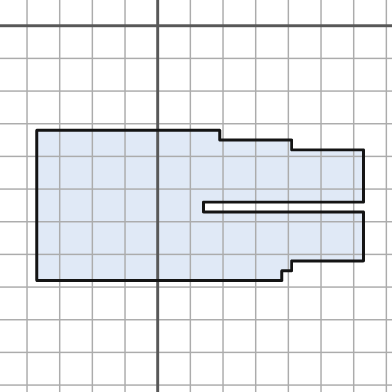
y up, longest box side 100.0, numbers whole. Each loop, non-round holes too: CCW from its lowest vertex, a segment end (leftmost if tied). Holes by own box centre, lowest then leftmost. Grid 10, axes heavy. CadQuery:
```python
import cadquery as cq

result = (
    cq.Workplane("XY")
    .moveTo(-37.0, -78.0)
    .lineTo(38.0, -78.0)
    .lineTo(38.0, -75.0)
    .lineTo(41.0, -75.0)
    .lineTo(41.0, -72.0)
    .lineTo(63.0, -72.0)
    .lineTo(63.0, -57.0)
    .lineTo(14.0, -57.0)
    .lineTo(14.0, -54.0)
    .lineTo(63.0, -54.0)
    .lineTo(63.0, -38.0)
    .lineTo(41.0, -38.0)
    .lineTo(41.0, -35.0)
    .lineTo(19.0, -35.0)
    .lineTo(19.0, -32.0)
    .lineTo(-37.0, -32.0)
    .close()
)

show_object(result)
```